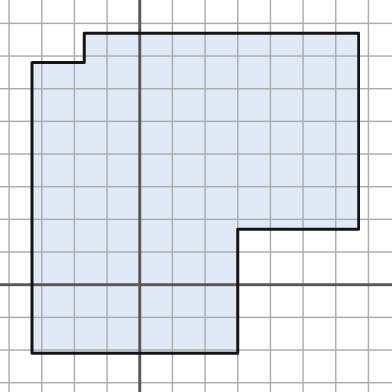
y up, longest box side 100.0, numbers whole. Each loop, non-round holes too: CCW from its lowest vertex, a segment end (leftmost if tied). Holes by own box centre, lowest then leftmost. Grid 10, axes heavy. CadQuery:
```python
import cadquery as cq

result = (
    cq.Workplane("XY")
    .moveTo(-33.0, -21.0)
    .lineTo(30.0, -21.0)
    .lineTo(30.0, 17.0)
    .lineTo(67.0, 17.0)
    .lineTo(67.0, 77.0)
    .lineTo(-17.0, 77.0)
    .lineTo(-17.0, 68.0)
    .lineTo(-33.0, 68.0)
    .close()
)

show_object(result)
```